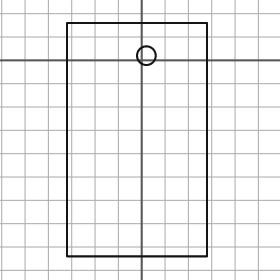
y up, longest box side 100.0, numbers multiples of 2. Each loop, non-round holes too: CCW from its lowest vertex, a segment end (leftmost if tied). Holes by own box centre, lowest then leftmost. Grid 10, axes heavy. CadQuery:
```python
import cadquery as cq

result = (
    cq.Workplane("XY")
    .moveTo(-32.0, -84.0)
    .lineTo(28.0, -84.0)
    .lineTo(28.0, 16.0)
    .lineTo(-32.0, 16.0)
    .close()
    .moveTo(2.0, 2.0)
    .circle(4.0)
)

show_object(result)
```